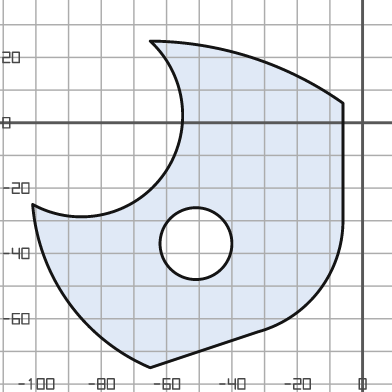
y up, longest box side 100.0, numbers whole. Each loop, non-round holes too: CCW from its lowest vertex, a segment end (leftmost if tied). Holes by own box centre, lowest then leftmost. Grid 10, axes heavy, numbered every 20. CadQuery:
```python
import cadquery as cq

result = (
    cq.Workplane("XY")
    .moveTo(-65.0, -75.0)
    .lineTo(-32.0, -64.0)
    .threePointArc((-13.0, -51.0), (-6.0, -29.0))
    .lineTo(-6.0, 6.0)
    .threePointArc((-34.0, 20.0), (-65.0, 25.0))
    .threePointArc((-61.0, -16.0), (-101.0, -25.0))
    .threePointArc((-90.0, -55.0), (-65.0, -75.0))
    .close()
    .moveTo(-51.0, -37.0)
    .circle(11.0)
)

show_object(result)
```